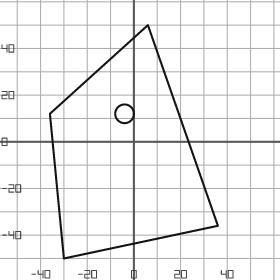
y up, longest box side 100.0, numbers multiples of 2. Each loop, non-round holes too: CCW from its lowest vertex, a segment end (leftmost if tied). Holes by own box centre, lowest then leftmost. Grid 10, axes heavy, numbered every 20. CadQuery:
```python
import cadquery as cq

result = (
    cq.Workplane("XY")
    .moveTo(-30.0, -50.0)
    .lineTo(36.0, -36.0)
    .lineTo(6.0, 50.0)
    .lineTo(-36.0, 12.0)
    .close()
    .moveTo(-4.0, 12.0)
    .circle(4.0)
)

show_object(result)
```